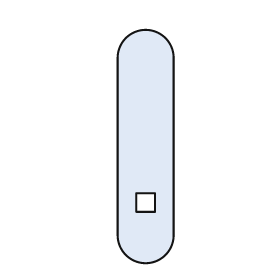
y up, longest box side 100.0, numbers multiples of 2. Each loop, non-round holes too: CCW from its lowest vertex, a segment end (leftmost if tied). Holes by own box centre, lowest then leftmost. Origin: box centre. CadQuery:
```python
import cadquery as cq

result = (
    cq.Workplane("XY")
    .moveTo(-12.0, -38.0)
    .threePointArc((0.0, -50.0), (12.0, -38.0))
    .lineTo(12.0, 38.0)
    .threePointArc((0.0, 50.0), (-12.0, 38.0))
    .close()
    .moveTo(-4.0, -28.0)
    .lineTo(4.0, -28.0)
    .lineTo(4.0, -20.0)
    .lineTo(-4.0, -20.0)
    .close()
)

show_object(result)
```